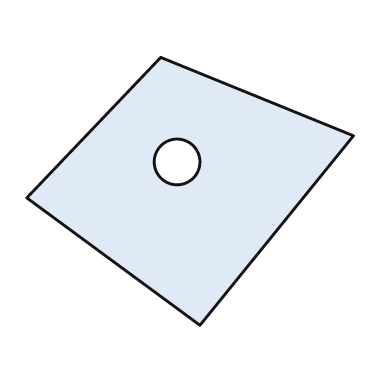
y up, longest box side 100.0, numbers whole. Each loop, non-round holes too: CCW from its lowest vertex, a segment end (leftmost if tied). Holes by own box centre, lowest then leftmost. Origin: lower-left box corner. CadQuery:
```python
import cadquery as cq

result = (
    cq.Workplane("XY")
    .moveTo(53.0, 0.0)
    .lineTo(100.0, 58.0)
    .lineTo(41.0, 82.0)
    .lineTo(0.0, 39.0)
    .close()
    .moveTo(46.0, 50.0)
    .circle(7.0)
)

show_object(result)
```